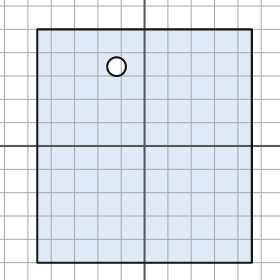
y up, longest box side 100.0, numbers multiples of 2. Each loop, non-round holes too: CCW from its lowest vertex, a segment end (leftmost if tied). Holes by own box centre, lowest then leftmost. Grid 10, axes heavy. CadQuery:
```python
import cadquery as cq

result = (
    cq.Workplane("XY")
    .moveTo(-46.0, -50.0)
    .lineTo(46.0, -50.0)
    .lineTo(46.0, 50.0)
    .lineTo(-46.0, 50.0)
    .close()
    .moveTo(-12.0, 34.0)
    .circle(4.0)
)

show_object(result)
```